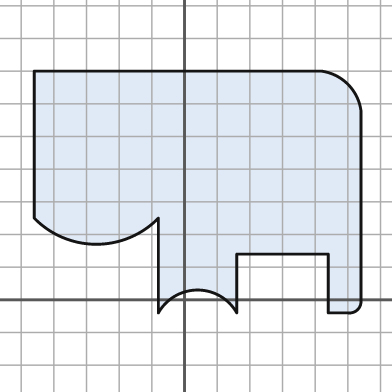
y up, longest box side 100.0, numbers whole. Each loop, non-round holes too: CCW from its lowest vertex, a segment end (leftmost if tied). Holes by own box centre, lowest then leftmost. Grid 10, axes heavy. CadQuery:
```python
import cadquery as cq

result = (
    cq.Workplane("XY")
    .moveTo(-8.0, -4.0)
    .threePointArc((4.0, 3.0), (16.0, -4.0))
    .lineTo(16.0, 14.0)
    .lineTo(44.0, 14.0)
    .lineTo(44.0, -4.0)
    .lineTo(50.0, -4.0)
    .threePointArc((53.0, -3.0), (54.0, 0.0))
    .lineTo(54.0, 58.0)
    .threePointArc((50.0, 66.0), (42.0, 70.0))
    .lineTo(-46.0, 70.0)
    .lineTo(-46.0, 25.0)
    .threePointArc((-27.0, 17.0), (-8.0, 25.0))
    .close()
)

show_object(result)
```